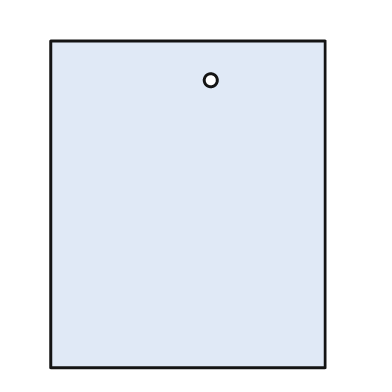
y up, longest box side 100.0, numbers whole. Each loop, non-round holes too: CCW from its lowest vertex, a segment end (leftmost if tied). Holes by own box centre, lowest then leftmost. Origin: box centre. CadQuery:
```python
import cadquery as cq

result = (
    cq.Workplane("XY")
    .moveTo(-42.0, -50.0)
    .lineTo(42.0, -50.0)
    .lineTo(42.0, 50.0)
    .lineTo(-42.0, 50.0)
    .close()
    .moveTo(7.0, 38.0)
    .circle(2.0)
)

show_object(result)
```